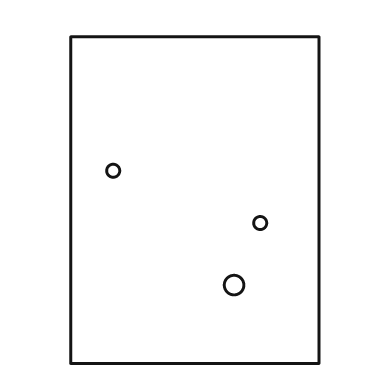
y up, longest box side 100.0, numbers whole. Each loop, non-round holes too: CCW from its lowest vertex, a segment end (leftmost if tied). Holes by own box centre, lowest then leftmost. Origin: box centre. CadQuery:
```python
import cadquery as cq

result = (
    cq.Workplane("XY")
    .moveTo(-38.0, -50.0)
    .lineTo(38.0, -50.0)
    .lineTo(38.0, 50.0)
    .lineTo(-38.0, 50.0)
    .close()
    .moveTo(12.0, -26.0)
    .circle(3.0)
    .moveTo(20.0, -7.0)
    .circle(2.0)
    .moveTo(-25.0, 9.0)
    .circle(2.0)
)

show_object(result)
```